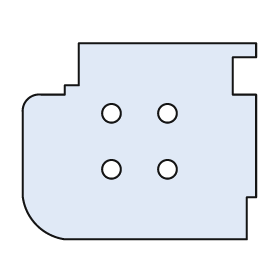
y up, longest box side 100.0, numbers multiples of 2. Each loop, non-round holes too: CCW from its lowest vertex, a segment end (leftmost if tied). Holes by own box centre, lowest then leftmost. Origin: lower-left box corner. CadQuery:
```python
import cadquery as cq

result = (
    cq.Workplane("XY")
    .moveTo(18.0, 0.0)
    .lineTo(96.0, 0.0)
    .lineTo(96.0, 18.0)
    .lineTo(100.0, 18.0)
    .lineTo(100.0, 62.0)
    .lineTo(90.0, 62.0)
    .lineTo(90.0, 78.0)
    .lineTo(100.0, 78.0)
    .lineTo(100.0, 84.0)
    .lineTo(24.0, 84.0)
    .lineTo(24.0, 66.0)
    .lineTo(18.0, 66.0)
    .lineTo(18.0, 62.0)
    .lineTo(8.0, 62.0)
    .threePointArc((2.0, 60.0), (0.0, 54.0))
    .lineTo(0.0, 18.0)
    .threePointArc((6.0, 6.0), (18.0, 0.0))
    .close()
    .moveTo(38.0, 30.0)
    .circle(4.0)
    .moveTo(62.0, 30.0)
    .circle(4.0)
    .moveTo(38.0, 54.0)
    .circle(4.0)
    .moveTo(62.0, 54.0)
    .circle(4.0)
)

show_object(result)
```